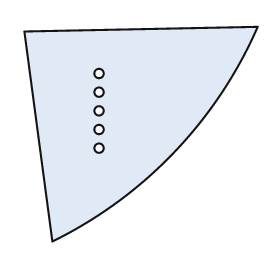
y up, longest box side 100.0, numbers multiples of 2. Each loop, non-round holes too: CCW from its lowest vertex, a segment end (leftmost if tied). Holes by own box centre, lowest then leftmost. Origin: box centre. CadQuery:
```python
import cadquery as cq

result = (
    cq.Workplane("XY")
    .moveTo(-38.0, -46.0)
    .threePointArc((14.0, -8.0), (50.0, 46.0))
    .lineTo(-50.0, 44.0)
    .close()
    .moveTo(-18.0, -6.0)
    .circle(2.0)
    .moveTo(-18.0, 2.0)
    .circle(2.0)
    .moveTo(-18.0, 10.0)
    .circle(2.0)
    .moveTo(-18.0, 18.0)
    .circle(2.0)
    .moveTo(-18.0, 26.0)
    .circle(2.0)
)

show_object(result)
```